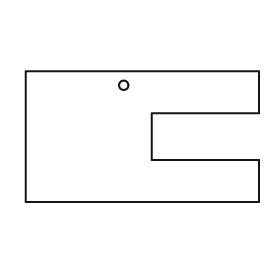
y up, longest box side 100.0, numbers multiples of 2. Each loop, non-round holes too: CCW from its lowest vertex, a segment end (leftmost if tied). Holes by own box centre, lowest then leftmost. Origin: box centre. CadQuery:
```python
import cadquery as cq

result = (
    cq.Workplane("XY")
    .moveTo(-50.0, -28.0)
    .lineTo(50.0, -28.0)
    .lineTo(50.0, -10.0)
    .lineTo(4.0, -10.0)
    .lineTo(4.0, 10.0)
    .lineTo(50.0, 10.0)
    .lineTo(50.0, 28.0)
    .lineTo(-50.0, 28.0)
    .close()
    .moveTo(-8.0, 22.0)
    .circle(2.0)
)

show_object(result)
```